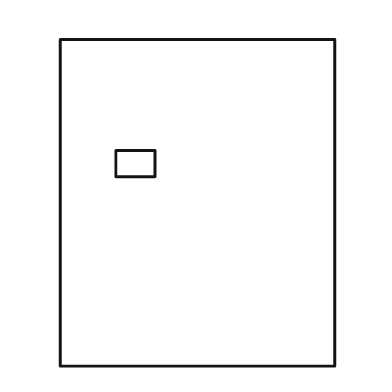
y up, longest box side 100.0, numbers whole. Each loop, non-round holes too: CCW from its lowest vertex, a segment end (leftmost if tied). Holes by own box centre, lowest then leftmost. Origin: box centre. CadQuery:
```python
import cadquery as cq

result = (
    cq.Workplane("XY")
    .moveTo(-42.0, -50.0)
    .lineTo(42.0, -50.0)
    .lineTo(42.0, 50.0)
    .lineTo(-42.0, 50.0)
    .close()
    .moveTo(-25.0, 8.0)
    .lineTo(-13.0, 8.0)
    .lineTo(-13.0, 16.0)
    .lineTo(-25.0, 16.0)
    .close()
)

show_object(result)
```